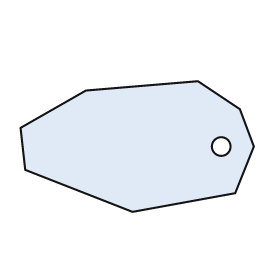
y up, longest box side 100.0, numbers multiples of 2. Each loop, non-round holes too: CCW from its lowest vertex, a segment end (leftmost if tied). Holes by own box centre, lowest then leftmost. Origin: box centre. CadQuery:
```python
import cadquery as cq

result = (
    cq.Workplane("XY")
    .moveTo(-2.0, -28.0)
    .lineTo(42.0, -20.0)
    .lineTo(50.0, 0.0)
    .lineTo(44.0, 16.0)
    .lineTo(26.0, 28.0)
    .lineTo(-22.0, 24.0)
    .lineTo(-50.0, 8.0)
    .lineTo(-48.0, -10.0)
    .close()
    .moveTo(36.0, 0.0)
    .circle(4.0)
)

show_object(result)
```